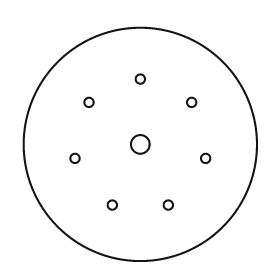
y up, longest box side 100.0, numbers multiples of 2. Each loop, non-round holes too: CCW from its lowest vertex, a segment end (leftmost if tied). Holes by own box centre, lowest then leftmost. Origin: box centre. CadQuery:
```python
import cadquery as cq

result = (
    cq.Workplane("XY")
    .moveTo(0.0, 0.0)
    .circle(50.0)
    .moveTo(-12.0, -26.0)
    .circle(2.0)
    .moveTo(12.0, -26.0)
    .circle(2.0)
    .moveTo(-28.0, -6.0)
    .circle(2.0)
    .moveTo(28.0, -6.0)
    .circle(2.0)
    .moveTo(0.0, 0.0)
    .circle(4.0)
    .moveTo(-22.0, 18.0)
    .circle(2.0)
    .moveTo(22.0, 18.0)
    .circle(2.0)
    .moveTo(0.0, 28.0)
    .circle(2.0)
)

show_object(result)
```